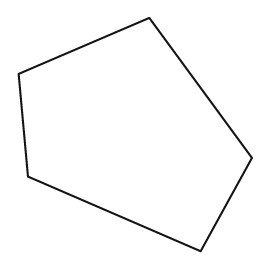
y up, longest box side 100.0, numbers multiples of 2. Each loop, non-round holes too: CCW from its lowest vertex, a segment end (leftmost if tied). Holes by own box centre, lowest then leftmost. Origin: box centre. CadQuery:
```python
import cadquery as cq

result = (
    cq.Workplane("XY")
    .moveTo(28.0, -50.0)
    .lineTo(50.0, -10.0)
    .lineTo(6.0, 50.0)
    .lineTo(-50.0, 26.0)
    .lineTo(-46.0, -18.0)
    .close()
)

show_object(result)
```